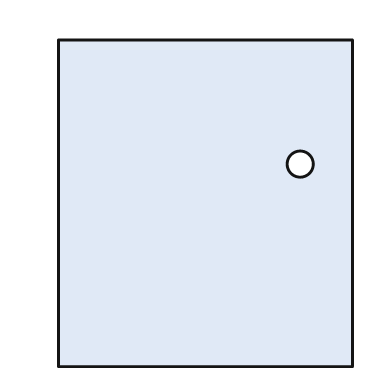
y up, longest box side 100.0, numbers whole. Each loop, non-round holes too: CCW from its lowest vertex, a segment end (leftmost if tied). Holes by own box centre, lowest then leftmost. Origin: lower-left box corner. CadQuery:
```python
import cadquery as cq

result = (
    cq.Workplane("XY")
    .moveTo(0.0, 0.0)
    .lineTo(90.0, 0.0)
    .lineTo(90.0, 100.0)
    .lineTo(0.0, 100.0)
    .close()
    .moveTo(74.0, 62.0)
    .circle(4.0)
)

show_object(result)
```